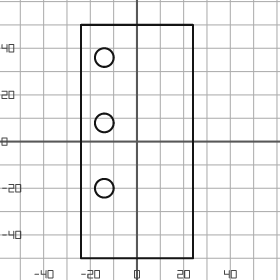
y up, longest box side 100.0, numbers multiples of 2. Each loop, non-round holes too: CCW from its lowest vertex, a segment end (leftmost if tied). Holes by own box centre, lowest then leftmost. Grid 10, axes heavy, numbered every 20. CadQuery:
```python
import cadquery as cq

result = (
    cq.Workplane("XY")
    .moveTo(-24.0, -50.0)
    .lineTo(24.0, -50.0)
    .lineTo(24.0, 50.0)
    .lineTo(-24.0, 50.0)
    .close()
    .moveTo(-14.0, -20.0)
    .circle(4.0)
    .moveTo(-14.0, 8.0)
    .circle(4.0)
    .moveTo(-14.0, 36.0)
    .circle(4.0)
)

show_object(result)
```